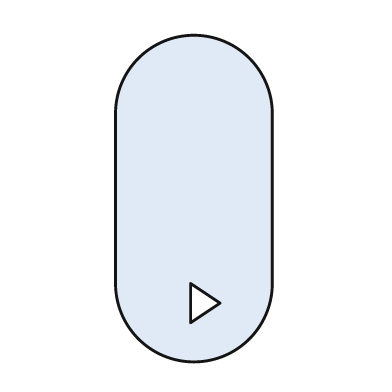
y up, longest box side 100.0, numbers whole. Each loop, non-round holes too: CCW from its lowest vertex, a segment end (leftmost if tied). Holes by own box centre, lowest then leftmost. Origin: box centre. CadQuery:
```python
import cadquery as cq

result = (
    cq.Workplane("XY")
    .moveTo(-24.0, -26.0)
    .threePointArc((0.0, -50.0), (24.0, -26.0))
    .lineTo(24.0, 26.0)
    .threePointArc((0.0, 50.0), (-24.0, 26.0))
    .close()
    .moveTo(-1.0, -38.0)
    .lineTo(8.0, -32.0)
    .lineTo(-1.0, -26.0)
    .close()
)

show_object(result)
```